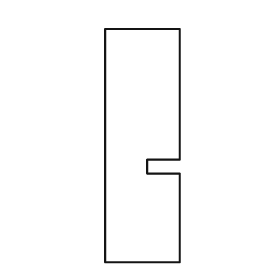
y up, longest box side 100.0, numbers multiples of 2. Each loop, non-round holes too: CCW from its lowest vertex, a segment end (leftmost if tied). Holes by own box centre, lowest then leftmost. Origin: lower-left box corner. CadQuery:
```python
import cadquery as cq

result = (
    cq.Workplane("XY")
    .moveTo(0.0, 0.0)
    .lineTo(32.0, 0.0)
    .lineTo(32.0, 38.0)
    .lineTo(18.0, 38.0)
    .lineTo(18.0, 44.0)
    .lineTo(32.0, 44.0)
    .lineTo(32.0, 100.0)
    .lineTo(0.0, 100.0)
    .close()
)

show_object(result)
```